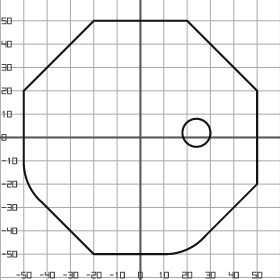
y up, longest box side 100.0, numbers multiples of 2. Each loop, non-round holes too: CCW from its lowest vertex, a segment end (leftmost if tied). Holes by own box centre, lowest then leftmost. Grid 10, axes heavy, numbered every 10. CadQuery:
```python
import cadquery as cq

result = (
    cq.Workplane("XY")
    .moveTo(-20.0, -50.0)
    .lineTo(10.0, -50.0)
    .threePointArc((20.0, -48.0), (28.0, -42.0))
    .lineTo(50.0, -20.0)
    .lineTo(50.0, 20.0)
    .lineTo(20.0, 50.0)
    .lineTo(-20.0, 50.0)
    .lineTo(-50.0, 20.0)
    .lineTo(-50.0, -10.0)
    .threePointArc((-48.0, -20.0), (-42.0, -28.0))
    .close()
    .moveTo(24.0, 2.0)
    .circle(6.0)
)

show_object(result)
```